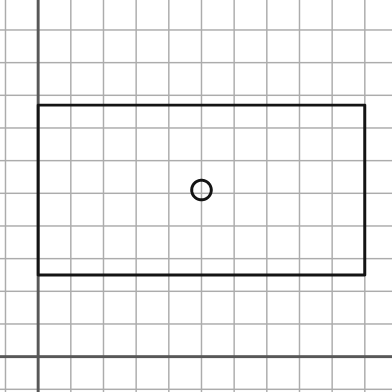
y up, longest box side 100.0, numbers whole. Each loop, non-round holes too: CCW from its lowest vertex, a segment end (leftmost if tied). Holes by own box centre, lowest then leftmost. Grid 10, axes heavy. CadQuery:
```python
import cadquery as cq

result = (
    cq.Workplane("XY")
    .moveTo(0.0, 25.0)
    .lineTo(100.0, 25.0)
    .lineTo(100.0, 77.0)
    .lineTo(0.0, 77.0)
    .close()
    .moveTo(50.0, 51.0)
    .circle(3.0)
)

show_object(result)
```